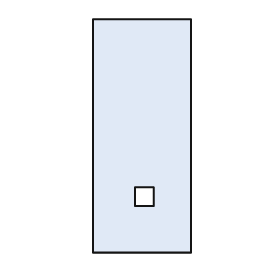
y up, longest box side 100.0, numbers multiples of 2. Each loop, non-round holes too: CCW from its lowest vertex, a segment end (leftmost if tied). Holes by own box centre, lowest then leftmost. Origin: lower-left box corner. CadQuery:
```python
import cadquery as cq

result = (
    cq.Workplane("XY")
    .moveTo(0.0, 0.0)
    .lineTo(42.0, 0.0)
    .lineTo(42.0, 100.0)
    .lineTo(0.0, 100.0)
    .close()
    .moveTo(18.0, 20.0)
    .lineTo(26.0, 20.0)
    .lineTo(26.0, 28.0)
    .lineTo(18.0, 28.0)
    .close()
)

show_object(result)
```